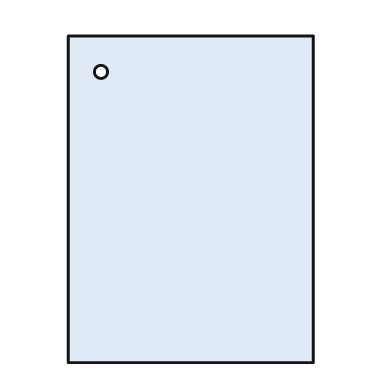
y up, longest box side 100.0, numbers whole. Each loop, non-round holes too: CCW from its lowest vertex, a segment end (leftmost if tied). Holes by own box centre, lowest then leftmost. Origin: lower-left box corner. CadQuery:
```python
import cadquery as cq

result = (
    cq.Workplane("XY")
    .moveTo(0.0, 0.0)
    .lineTo(75.0, 0.0)
    .lineTo(75.0, 100.0)
    .lineTo(0.0, 100.0)
    .close()
    .moveTo(10.0, 89.0)
    .circle(2.0)
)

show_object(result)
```